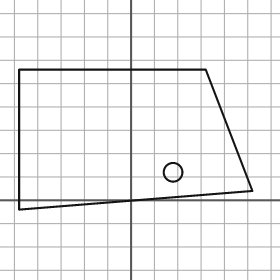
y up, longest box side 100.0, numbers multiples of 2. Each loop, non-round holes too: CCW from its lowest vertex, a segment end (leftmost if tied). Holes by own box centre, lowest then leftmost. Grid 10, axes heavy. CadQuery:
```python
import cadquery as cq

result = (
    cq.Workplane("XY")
    .moveTo(-48.0, -4.0)
    .lineTo(52.0, 4.0)
    .lineTo(32.0, 56.0)
    .lineTo(-48.0, 56.0)
    .close()
    .moveTo(18.0, 12.0)
    .circle(4.0)
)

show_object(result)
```